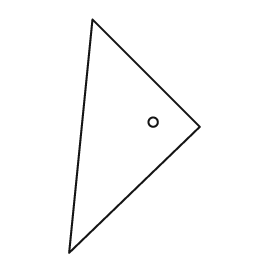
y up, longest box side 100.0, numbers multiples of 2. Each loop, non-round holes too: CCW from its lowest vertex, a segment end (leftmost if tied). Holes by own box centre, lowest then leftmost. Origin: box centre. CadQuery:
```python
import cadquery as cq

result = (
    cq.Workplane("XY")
    .moveTo(-28.0, -50.0)
    .lineTo(28.0, 4.0)
    .lineTo(-18.0, 50.0)
    .close()
    .moveTo(8.0, 6.0)
    .circle(2.0)
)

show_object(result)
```